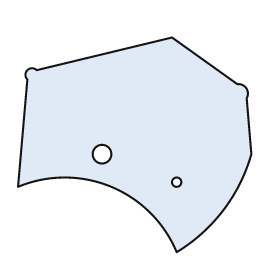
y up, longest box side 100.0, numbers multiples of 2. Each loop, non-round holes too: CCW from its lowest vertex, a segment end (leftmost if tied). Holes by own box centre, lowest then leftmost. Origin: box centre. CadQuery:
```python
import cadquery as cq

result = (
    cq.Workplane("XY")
    .moveTo(18.0, -46.0)
    .threePointArc((38.0, -28.0), (50.0, -4.0))
    .lineTo(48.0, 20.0)
    .threePointArc((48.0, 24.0), (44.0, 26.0))
    .lineTo(16.0, 46.0)
    .lineTo(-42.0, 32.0)
    .threePointArc((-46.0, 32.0), (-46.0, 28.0))
    .lineTo(-50.0, -18.0)
    .threePointArc((-10.0, -18.0), (18.0, -46.0))
    .close()
    .moveTo(18.0, -16.0)
    .circle(2.0)
    .moveTo(-14.0, -4.0)
    .circle(4.0)
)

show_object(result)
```